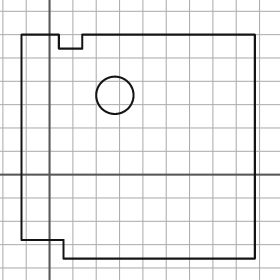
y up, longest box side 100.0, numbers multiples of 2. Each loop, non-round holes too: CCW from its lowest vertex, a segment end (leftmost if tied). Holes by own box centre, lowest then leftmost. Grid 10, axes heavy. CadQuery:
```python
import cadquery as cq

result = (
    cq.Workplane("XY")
    .moveTo(6.0, -36.0)
    .lineTo(88.0, -36.0)
    .lineTo(88.0, 60.0)
    .lineTo(14.0, 60.0)
    .lineTo(14.0, 54.0)
    .lineTo(4.0, 54.0)
    .lineTo(4.0, 60.0)
    .lineTo(-12.0, 60.0)
    .lineTo(-12.0, -28.0)
    .lineTo(6.0, -28.0)
    .close()
    .moveTo(28.0, 34.0)
    .circle(8.0)
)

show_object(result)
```